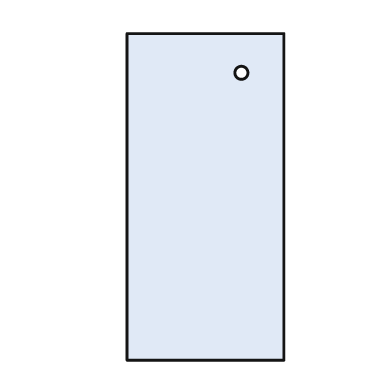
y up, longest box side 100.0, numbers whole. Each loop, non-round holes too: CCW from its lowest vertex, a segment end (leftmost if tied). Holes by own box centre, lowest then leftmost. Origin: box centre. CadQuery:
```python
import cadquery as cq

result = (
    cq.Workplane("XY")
    .moveTo(-24.0, -50.0)
    .lineTo(24.0, -50.0)
    .lineTo(24.0, 50.0)
    .lineTo(-24.0, 50.0)
    .close()
    .moveTo(11.0, 38.0)
    .circle(2.0)
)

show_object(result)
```